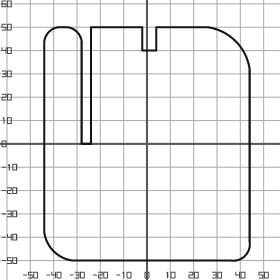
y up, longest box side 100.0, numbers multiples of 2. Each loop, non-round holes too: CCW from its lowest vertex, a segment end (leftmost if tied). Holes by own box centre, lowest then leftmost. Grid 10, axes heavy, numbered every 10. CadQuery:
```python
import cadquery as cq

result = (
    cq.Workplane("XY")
    .moveTo(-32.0, -50.0)
    .lineTo(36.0, -50.0)
    .threePointArc((42.0, -48.0), (44.0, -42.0))
    .lineTo(44.0, 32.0)
    .threePointArc((38.0, 44.0), (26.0, 50.0))
    .lineTo(4.0, 50.0)
    .lineTo(4.0, 40.0)
    .lineTo(-2.0, 40.0)
    .lineTo(-2.0, 50.0)
    .lineTo(-24.0, 50.0)
    .lineTo(-24.0, 0.0)
    .lineTo(-28.0, 0.0)
    .lineTo(-28.0, 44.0)
    .threePointArc((-30.0, 48.0), (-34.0, 50.0))
    .lineTo(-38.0, 50.0)
    .threePointArc((-42.0, 48.0), (-44.0, 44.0))
    .lineTo(-44.0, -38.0)
    .threePointArc((-40.0, -46.0), (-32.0, -50.0))
    .close()
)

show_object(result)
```